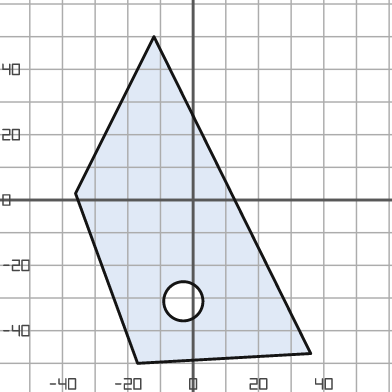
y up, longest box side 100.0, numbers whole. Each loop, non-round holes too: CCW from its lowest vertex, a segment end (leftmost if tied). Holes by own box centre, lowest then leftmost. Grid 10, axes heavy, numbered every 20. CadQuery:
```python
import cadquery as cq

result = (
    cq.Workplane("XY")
    .moveTo(-17.0, -50.0)
    .lineTo(36.0, -47.0)
    .lineTo(-12.0, 50.0)
    .lineTo(-36.0, 2.0)
    .close()
    .moveTo(-3.0, -31.0)
    .circle(6.0)
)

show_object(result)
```